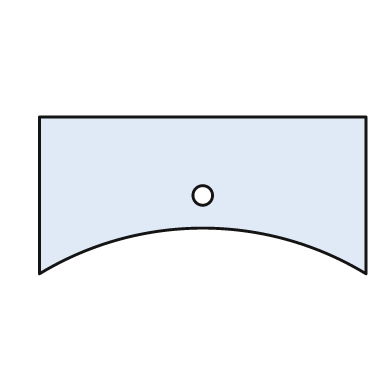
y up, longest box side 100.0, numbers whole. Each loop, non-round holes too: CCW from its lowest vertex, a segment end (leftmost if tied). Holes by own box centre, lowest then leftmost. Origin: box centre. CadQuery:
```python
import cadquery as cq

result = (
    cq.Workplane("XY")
    .moveTo(-50.0, -24.0)
    .threePointArc((0.0, -10.0), (50.0, -24.0))
    .lineTo(50.0, 24.0)
    .lineTo(-50.0, 24.0)
    .close()
    .moveTo(0.0, 0.0)
    .circle(3.0)
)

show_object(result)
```